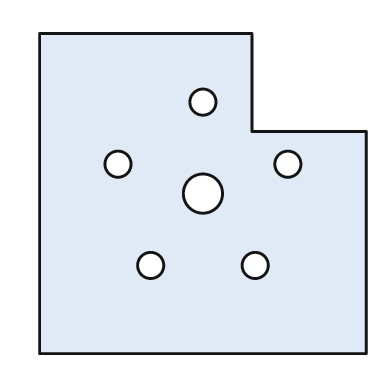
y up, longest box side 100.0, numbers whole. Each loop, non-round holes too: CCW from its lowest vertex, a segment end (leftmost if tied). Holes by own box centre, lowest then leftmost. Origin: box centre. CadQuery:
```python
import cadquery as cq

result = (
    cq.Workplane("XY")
    .moveTo(-50.0, -49.0)
    .lineTo(50.0, -49.0)
    .lineTo(50.0, 19.0)
    .lineTo(15.0, 19.0)
    .lineTo(15.0, 49.0)
    .lineTo(-50.0, 49.0)
    .close()
    .moveTo(-16.0, -22.0)
    .circle(4.0)
    .moveTo(16.0, -22.0)
    .circle(4.0)
    .moveTo(0.0, 0.0)
    .circle(6.0)
    .moveTo(-26.0, 9.0)
    .circle(4.0)
    .moveTo(26.0, 9.0)
    .circle(4.0)
    .moveTo(0.0, 28.0)
    .circle(4.0)
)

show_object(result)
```